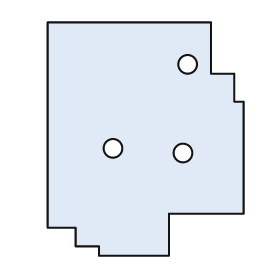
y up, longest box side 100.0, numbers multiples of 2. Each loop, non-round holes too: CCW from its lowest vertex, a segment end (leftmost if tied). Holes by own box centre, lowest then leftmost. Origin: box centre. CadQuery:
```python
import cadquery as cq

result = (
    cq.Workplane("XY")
    .moveTo(-20.0, -50.0)
    .lineTo(10.0, -50.0)
    .lineTo(10.0, -32.0)
    .lineTo(42.0, -32.0)
    .lineTo(42.0, 16.0)
    .lineTo(38.0, 16.0)
    .lineTo(38.0, 28.0)
    .lineTo(28.0, 28.0)
    .lineTo(28.0, 50.0)
    .lineTo(-42.0, 50.0)
    .lineTo(-42.0, -38.0)
    .lineTo(-30.0, -38.0)
    .lineTo(-30.0, -46.0)
    .lineTo(-20.0, -46.0)
    .close()
    .moveTo(16.0, -6.0)
    .circle(4.0)
    .moveTo(-14.0, -4.0)
    .circle(4.0)
    .moveTo(18.0, 32.0)
    .circle(4.0)
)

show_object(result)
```